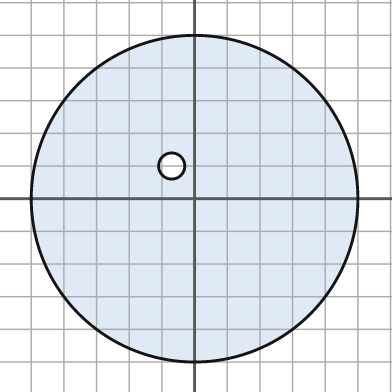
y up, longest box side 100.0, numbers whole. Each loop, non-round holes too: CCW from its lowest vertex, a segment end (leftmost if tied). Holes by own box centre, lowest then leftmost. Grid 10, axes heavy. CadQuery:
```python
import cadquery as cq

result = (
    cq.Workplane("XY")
    .moveTo(0.0, 0.0)
    .circle(50.0)
    .moveTo(-7.0, 10.0)
    .circle(4.0)
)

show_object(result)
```